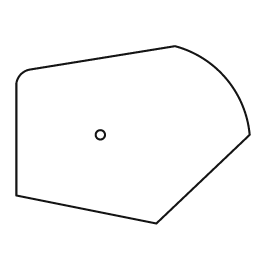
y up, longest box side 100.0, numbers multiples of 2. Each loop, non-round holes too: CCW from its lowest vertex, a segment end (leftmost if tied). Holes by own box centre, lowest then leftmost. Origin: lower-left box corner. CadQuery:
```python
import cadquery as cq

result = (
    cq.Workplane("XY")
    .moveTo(60.0, 0.0)
    .lineTo(100.0, 38.0)
    .threePointArc((90.0, 62.0), (68.0, 76.0))
    .lineTo(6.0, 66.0)
    .threePointArc((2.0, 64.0), (0.0, 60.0))
    .lineTo(0.0, 12.0)
    .close()
    .moveTo(36.0, 38.0)
    .circle(2.0)
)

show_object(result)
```